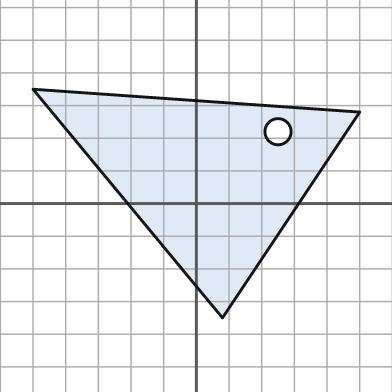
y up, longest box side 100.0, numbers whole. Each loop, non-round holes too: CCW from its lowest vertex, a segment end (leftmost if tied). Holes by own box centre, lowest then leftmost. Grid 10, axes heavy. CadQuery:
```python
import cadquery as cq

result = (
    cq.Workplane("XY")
    .moveTo(8.0, -35.0)
    .lineTo(50.0, 28.0)
    .lineTo(-50.0, 35.0)
    .close()
    .moveTo(25.0, 22.0)
    .circle(4.0)
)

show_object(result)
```